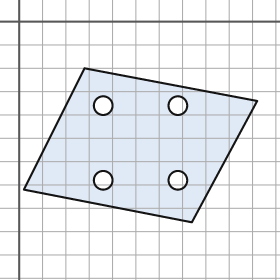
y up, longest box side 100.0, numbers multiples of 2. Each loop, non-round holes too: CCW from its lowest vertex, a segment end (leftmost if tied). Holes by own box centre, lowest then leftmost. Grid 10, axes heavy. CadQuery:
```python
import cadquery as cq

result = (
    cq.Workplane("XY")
    .moveTo(74.0, -86.0)
    .lineTo(102.0, -34.0)
    .lineTo(28.0, -20.0)
    .lineTo(2.0, -72.0)
    .close()
    .moveTo(36.0, -68.0)
    .circle(4.0)
    .moveTo(68.0, -68.0)
    .circle(4.0)
    .moveTo(36.0, -36.0)
    .circle(4.0)
    .moveTo(68.0, -36.0)
    .circle(4.0)
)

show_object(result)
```